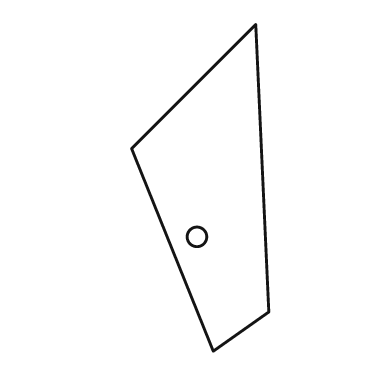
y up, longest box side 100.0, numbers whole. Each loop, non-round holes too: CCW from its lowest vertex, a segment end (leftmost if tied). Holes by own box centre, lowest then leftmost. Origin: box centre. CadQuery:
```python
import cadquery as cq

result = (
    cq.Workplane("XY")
    .moveTo(4.0, -50.0)
    .lineTo(21.0, -38.0)
    .lineTo(17.0, 50.0)
    .lineTo(-21.0, 12.0)
    .close()
    .moveTo(-1.0, -15.0)
    .circle(3.0)
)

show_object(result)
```